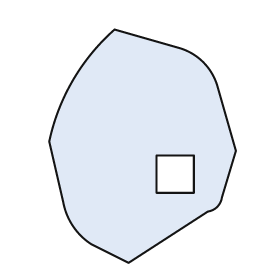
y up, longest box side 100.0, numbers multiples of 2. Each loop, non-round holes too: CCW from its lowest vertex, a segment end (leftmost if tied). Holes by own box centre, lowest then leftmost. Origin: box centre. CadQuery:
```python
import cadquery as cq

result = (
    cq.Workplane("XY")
    .moveTo(-6.0, -50.0)
    .lineTo(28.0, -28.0)
    .threePointArc((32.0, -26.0), (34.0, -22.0))
    .lineTo(40.0, -2.0)
    .lineTo(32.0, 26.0)
    .threePointArc((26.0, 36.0), (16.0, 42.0))
    .lineTo(-12.0, 50.0)
    .threePointArc((-30.0, 28.0), (-40.0, 2.0))
    .lineTo(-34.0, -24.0)
    .threePointArc((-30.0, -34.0), (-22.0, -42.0))
    .close()
    .moveTo(6.0, -20.0)
    .lineTo(22.0, -20.0)
    .lineTo(22.0, -4.0)
    .lineTo(6.0, -4.0)
    .close()
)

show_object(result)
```